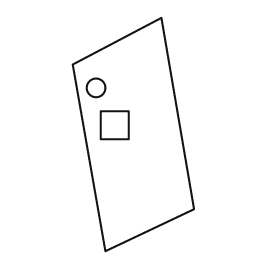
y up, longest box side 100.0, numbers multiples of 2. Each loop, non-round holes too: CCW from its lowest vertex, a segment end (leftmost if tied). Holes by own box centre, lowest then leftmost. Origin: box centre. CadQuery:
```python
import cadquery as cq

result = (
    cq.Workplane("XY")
    .moveTo(-12.0, -50.0)
    .lineTo(26.0, -32.0)
    .lineTo(12.0, 50.0)
    .lineTo(-26.0, 30.0)
    .close()
    .moveTo(-14.0, -2.0)
    .lineTo(-2.0, -2.0)
    .lineTo(-2.0, 10.0)
    .lineTo(-14.0, 10.0)
    .close()
    .moveTo(-16.0, 20.0)
    .circle(4.0)
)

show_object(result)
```